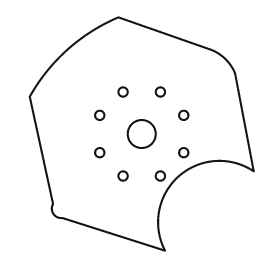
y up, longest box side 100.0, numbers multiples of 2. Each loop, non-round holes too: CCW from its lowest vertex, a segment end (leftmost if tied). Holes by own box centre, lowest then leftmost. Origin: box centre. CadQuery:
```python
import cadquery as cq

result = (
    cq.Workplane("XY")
    .moveTo(10.0, -50.0)
    .threePointArc((16.0, -18.0), (48.0, -16.0))
    .lineTo(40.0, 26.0)
    .threePointArc((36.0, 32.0), (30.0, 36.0))
    .lineTo(-10.0, 50.0)
    .threePointArc((-32.0, 36.0), (-48.0, 16.0))
    .lineTo(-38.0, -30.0)
    .threePointArc((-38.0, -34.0), (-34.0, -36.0))
    .close()
    .moveTo(-8.0, -18.0)
    .circle(2.0)
    .moveTo(8.0, -18.0)
    .circle(2.0)
    .moveTo(-18.0, -8.0)
    .circle(2.0)
    .moveTo(18.0, -8.0)
    .circle(2.0)
    .moveTo(0.0, 0.0)
    .circle(6.0)
    .moveTo(-18.0, 8.0)
    .circle(2.0)
    .moveTo(18.0, 8.0)
    .circle(2.0)
    .moveTo(-8.0, 18.0)
    .circle(2.0)
    .moveTo(8.0, 18.0)
    .circle(2.0)
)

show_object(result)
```